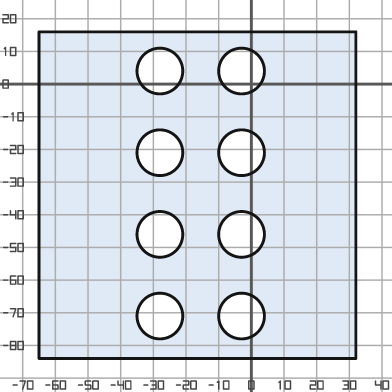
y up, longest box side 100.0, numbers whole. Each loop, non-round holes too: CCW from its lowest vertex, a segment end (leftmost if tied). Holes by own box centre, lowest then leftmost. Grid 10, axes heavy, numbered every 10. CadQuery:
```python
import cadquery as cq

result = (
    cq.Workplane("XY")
    .moveTo(-65.0, -84.0)
    .lineTo(32.0, -84.0)
    .lineTo(32.0, 16.0)
    .lineTo(-65.0, 16.0)
    .close()
    .moveTo(-28.0, -71.0)
    .circle(7.0)
    .moveTo(-3.0, -71.0)
    .circle(7.0)
    .moveTo(-28.0, -46.0)
    .circle(7.0)
    .moveTo(-3.0, -46.0)
    .circle(7.0)
    .moveTo(-28.0, -21.0)
    .circle(7.0)
    .moveTo(-3.0, -21.0)
    .circle(7.0)
    .moveTo(-28.0, 4.0)
    .circle(7.0)
    .moveTo(-3.0, 4.0)
    .circle(7.0)
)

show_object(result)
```